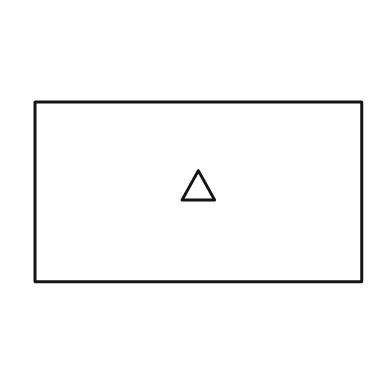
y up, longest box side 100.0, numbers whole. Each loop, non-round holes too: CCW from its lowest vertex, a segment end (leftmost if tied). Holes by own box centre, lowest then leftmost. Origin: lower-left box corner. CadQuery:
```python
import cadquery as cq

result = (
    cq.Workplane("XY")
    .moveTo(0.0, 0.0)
    .lineTo(100.0, 0.0)
    .lineTo(100.0, 55.0)
    .lineTo(0.0, 55.0)
    .close()
    .moveTo(45.0, 25.0)
    .lineTo(55.0, 25.0)
    .lineTo(50.0, 34.0)
    .close()
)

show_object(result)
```